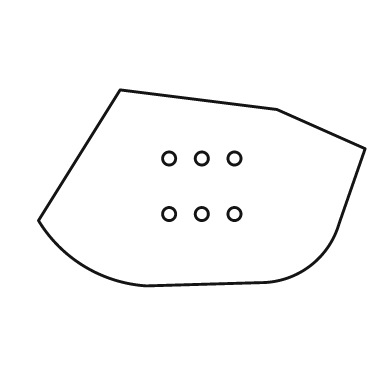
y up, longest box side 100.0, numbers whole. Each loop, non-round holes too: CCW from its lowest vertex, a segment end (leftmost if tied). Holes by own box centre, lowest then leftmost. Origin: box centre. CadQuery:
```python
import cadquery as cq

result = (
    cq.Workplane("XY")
    .moveTo(-17.0, -30.0)
    .lineTo(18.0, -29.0)
    .threePointArc((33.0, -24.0), (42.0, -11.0))
    .lineTo(50.0, 12.0)
    .lineTo(23.0, 24.0)
    .lineTo(-25.0, 30.0)
    .lineTo(-50.0, -10.0)
    .threePointArc((-36.0, -24.0), (-17.0, -30.0))
    .close()
    .moveTo(-10.0, -8.0)
    .circle(2.0)
    .moveTo(0.0, -8.0)
    .circle(2.0)
    .moveTo(10.0, -8.0)
    .circle(2.0)
    .moveTo(-10.0, 9.0)
    .circle(2.0)
    .moveTo(0.0, 9.0)
    .circle(2.0)
    .moveTo(10.0, 9.0)
    .circle(2.0)
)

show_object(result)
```